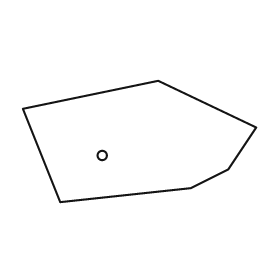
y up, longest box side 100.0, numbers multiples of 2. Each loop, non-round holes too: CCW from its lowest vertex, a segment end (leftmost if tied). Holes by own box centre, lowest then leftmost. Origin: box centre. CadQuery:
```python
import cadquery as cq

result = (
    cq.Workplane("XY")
    .moveTo(-34.0, -26.0)
    .lineTo(22.0, -20.0)
    .lineTo(38.0, -12.0)
    .lineTo(50.0, 6.0)
    .lineTo(8.0, 26.0)
    .lineTo(-50.0, 14.0)
    .close()
    .moveTo(-16.0, -6.0)
    .circle(2.0)
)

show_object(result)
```